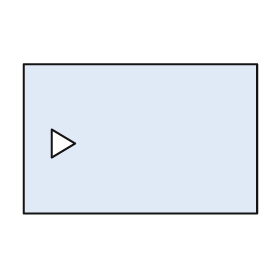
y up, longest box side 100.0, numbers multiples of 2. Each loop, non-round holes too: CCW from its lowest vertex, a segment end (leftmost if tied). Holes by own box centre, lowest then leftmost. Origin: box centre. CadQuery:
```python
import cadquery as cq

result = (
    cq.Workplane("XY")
    .moveTo(-50.0, -32.0)
    .lineTo(50.0, -32.0)
    .lineTo(50.0, 32.0)
    .lineTo(-50.0, 32.0)
    .close()
    .moveTo(-38.0, -8.0)
    .lineTo(-28.0, -2.0)
    .lineTo(-38.0, 4.0)
    .close()
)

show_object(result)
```